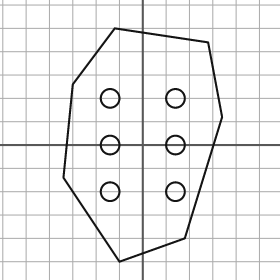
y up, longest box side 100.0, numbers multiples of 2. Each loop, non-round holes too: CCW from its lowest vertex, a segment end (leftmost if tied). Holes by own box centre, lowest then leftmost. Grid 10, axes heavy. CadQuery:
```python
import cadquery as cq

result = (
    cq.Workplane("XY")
    .moveTo(-10.0, -50.0)
    .lineTo(18.0, -40.0)
    .lineTo(34.0, 12.0)
    .lineTo(28.0, 44.0)
    .lineTo(-12.0, 50.0)
    .lineTo(-30.0, 26.0)
    .lineTo(-34.0, -14.0)
    .close()
    .moveTo(-14.0, -20.0)
    .circle(4.0)
    .moveTo(14.0, -20.0)
    .circle(4.0)
    .moveTo(-14.0, 0.0)
    .circle(4.0)
    .moveTo(14.0, 0.0)
    .circle(4.0)
    .moveTo(-14.0, 20.0)
    .circle(4.0)
    .moveTo(14.0, 20.0)
    .circle(4.0)
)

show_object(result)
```